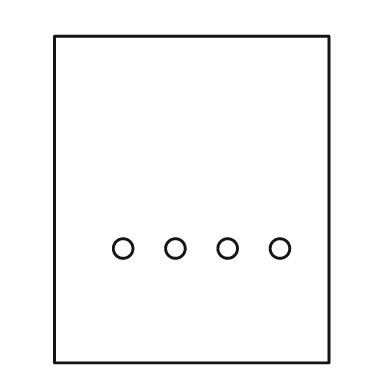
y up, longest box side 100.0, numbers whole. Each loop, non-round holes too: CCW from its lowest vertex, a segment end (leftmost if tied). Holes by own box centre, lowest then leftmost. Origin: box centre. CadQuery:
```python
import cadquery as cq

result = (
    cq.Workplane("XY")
    .moveTo(-42.0, -50.0)
    .lineTo(42.0, -50.0)
    .lineTo(42.0, 50.0)
    .lineTo(-42.0, 50.0)
    .close()
    .moveTo(-21.0, -15.0)
    .circle(3.0)
    .moveTo(-5.0, -15.0)
    .circle(3.0)
    .moveTo(11.0, -15.0)
    .circle(3.0)
    .moveTo(27.0, -15.0)
    .circle(3.0)
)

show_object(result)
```